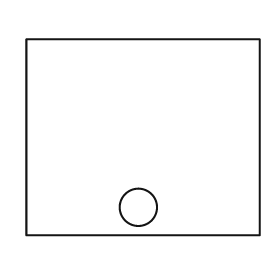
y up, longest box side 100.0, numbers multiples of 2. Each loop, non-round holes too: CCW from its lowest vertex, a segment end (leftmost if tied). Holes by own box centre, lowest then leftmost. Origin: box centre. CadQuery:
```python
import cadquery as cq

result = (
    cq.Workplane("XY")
    .moveTo(-50.0, -42.0)
    .lineTo(50.0, -42.0)
    .lineTo(50.0, 42.0)
    .lineTo(-50.0, 42.0)
    .close()
    .moveTo(-2.0, -30.0)
    .circle(8.0)
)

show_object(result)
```